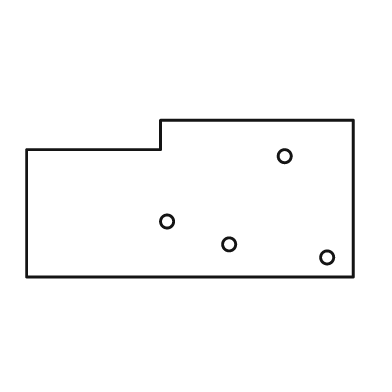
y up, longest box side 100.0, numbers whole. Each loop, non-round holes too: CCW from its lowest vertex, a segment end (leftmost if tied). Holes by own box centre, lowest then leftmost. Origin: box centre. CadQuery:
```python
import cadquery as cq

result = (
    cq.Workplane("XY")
    .moveTo(-50.0, -24.0)
    .lineTo(50.0, -24.0)
    .lineTo(50.0, 24.0)
    .lineTo(-9.0, 24.0)
    .lineTo(-9.0, 15.0)
    .lineTo(-50.0, 15.0)
    .close()
    .moveTo(42.0, -18.0)
    .circle(2.0)
    .moveTo(12.0, -14.0)
    .circle(2.0)
    .moveTo(-7.0, -7.0)
    .circle(2.0)
    .moveTo(29.0, 13.0)
    .circle(2.0)
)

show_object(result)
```